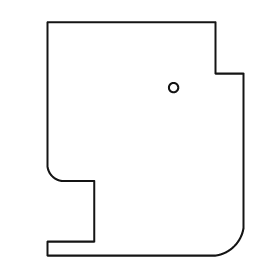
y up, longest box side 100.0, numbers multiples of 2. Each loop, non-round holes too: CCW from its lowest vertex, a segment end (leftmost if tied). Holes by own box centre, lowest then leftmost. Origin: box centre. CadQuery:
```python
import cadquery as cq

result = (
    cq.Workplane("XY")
    .moveTo(-42.0, -50.0)
    .lineTo(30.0, -50.0)
    .threePointArc((38.0, -46.0), (42.0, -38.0))
    .lineTo(42.0, 28.0)
    .lineTo(30.0, 28.0)
    .lineTo(30.0, 50.0)
    .lineTo(-42.0, 50.0)
    .lineTo(-42.0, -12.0)
    .threePointArc((-40.0, -16.0), (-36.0, -18.0))
    .lineTo(-22.0, -18.0)
    .lineTo(-22.0, -44.0)
    .lineTo(-42.0, -44.0)
    .close()
    .moveTo(12.0, 22.0)
    .circle(2.0)
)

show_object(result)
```